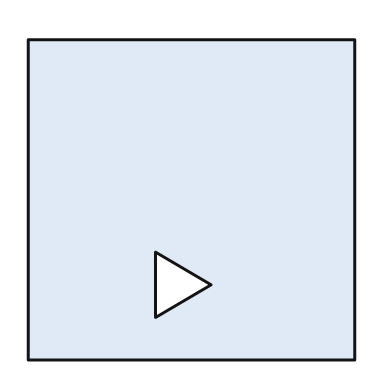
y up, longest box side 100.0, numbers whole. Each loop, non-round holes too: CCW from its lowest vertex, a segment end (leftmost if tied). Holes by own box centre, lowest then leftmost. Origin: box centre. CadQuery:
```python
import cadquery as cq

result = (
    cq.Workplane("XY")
    .moveTo(-50.0, -49.0)
    .lineTo(50.0, -49.0)
    .lineTo(50.0, 49.0)
    .lineTo(-50.0, 49.0)
    .close()
    .moveTo(-11.0, -36.0)
    .lineTo(6.0, -26.0)
    .lineTo(-11.0, -16.0)
    .close()
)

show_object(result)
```